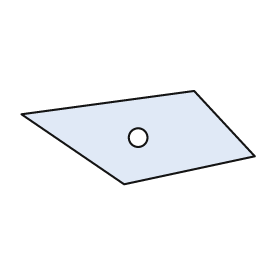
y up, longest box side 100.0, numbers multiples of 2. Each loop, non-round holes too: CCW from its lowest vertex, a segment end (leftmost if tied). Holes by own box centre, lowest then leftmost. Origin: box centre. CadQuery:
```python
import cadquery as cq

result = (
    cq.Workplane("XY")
    .moveTo(-6.0, -20.0)
    .lineTo(50.0, -8.0)
    .lineTo(24.0, 20.0)
    .lineTo(-50.0, 10.0)
    .close()
    .moveTo(0.0, 0.0)
    .circle(4.0)
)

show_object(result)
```